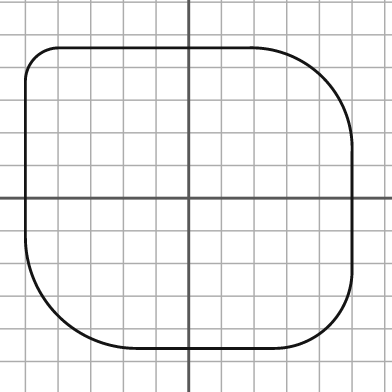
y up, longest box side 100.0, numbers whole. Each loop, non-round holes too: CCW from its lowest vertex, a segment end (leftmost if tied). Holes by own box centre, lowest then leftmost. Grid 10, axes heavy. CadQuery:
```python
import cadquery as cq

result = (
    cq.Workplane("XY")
    .moveTo(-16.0, -46.0)
    .lineTo(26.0, -46.0)
    .threePointArc((43.0, -39.0), (50.0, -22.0))
    .lineTo(50.0, 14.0)
    .threePointArc((41.0, 37.0), (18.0, 46.0))
    .lineTo(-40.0, 46.0)
    .threePointArc((-47.0, 43.0), (-50.0, 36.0))
    .lineTo(-50.0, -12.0)
    .threePointArc((-40.0, -36.0), (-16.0, -46.0))
    .close()
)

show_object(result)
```